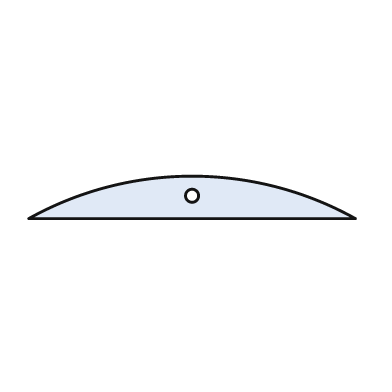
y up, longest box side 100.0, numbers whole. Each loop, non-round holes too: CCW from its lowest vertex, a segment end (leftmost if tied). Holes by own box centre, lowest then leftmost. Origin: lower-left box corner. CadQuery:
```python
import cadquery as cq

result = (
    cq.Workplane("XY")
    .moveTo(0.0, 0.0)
    .lineTo(100.0, 0.0)
    .threePointArc((50.0, 13.0), (0.0, 0.0))
    .close()
    .moveTo(50.0, 7.0)
    .circle(2.0)
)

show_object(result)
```